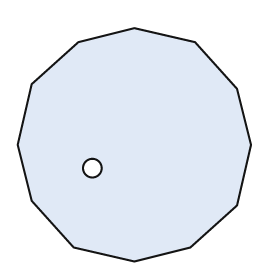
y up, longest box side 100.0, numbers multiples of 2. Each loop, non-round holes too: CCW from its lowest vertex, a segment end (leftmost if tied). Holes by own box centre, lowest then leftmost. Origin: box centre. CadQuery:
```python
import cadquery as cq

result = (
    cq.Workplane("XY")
    .moveTo(0.0, -50.0)
    .lineTo(24.0, -44.0)
    .lineTo(44.0, -26.0)
    .lineTo(50.0, 0.0)
    .lineTo(44.0, 24.0)
    .lineTo(26.0, 44.0)
    .lineTo(0.0, 50.0)
    .lineTo(-24.0, 44.0)
    .lineTo(-44.0, 26.0)
    .lineTo(-50.0, 0.0)
    .lineTo(-44.0, -24.0)
    .lineTo(-26.0, -44.0)
    .close()
    .moveTo(-18.0, -10.0)
    .circle(4.0)
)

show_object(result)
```